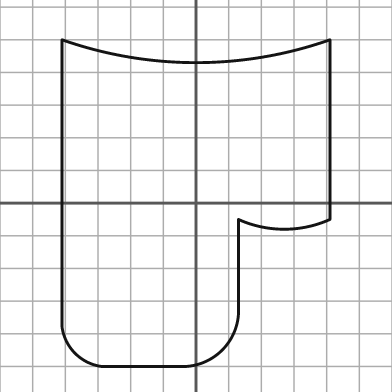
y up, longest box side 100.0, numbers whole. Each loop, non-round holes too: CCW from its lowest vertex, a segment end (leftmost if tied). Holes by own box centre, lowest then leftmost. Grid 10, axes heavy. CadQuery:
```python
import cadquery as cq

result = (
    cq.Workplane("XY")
    .moveTo(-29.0, -50.0)
    .lineTo(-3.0, -50.0)
    .threePointArc((8.0, -45.0), (13.0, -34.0))
    .lineTo(13.0, -5.0)
    .threePointArc((27.0, -8.0), (41.0, -5.0))
    .lineTo(41.0, 50.0)
    .threePointArc((0.0, 43.0), (-41.0, 50.0))
    .lineTo(-41.0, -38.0)
    .threePointArc((-37.0, -46.0), (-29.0, -50.0))
    .close()
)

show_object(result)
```